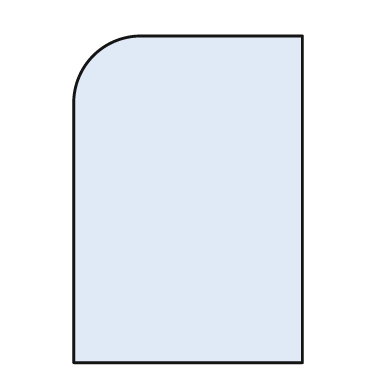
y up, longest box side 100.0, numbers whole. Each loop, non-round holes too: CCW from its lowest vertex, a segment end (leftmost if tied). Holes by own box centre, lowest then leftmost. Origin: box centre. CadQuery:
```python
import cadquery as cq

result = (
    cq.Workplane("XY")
    .moveTo(-35.0, -50.0)
    .lineTo(35.0, -50.0)
    .lineTo(35.0, 50.0)
    .lineTo(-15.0, 50.0)
    .threePointArc((-29.0, 44.0), (-35.0, 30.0))
    .close()
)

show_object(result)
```